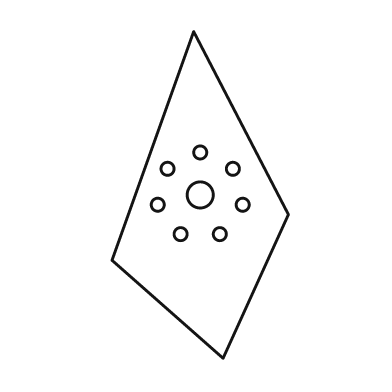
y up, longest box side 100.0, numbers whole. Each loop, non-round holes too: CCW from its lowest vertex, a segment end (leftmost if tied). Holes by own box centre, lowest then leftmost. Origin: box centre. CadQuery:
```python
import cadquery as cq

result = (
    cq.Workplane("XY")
    .moveTo(7.0, -50.0)
    .lineTo(27.0, -6.0)
    .lineTo(-2.0, 50.0)
    .lineTo(-27.0, -20.0)
    .close()
    .moveTo(-6.0, -12.0)
    .circle(2.0)
    .moveTo(6.0, -12.0)
    .circle(2.0)
    .moveTo(-13.0, -3.0)
    .circle(2.0)
    .moveTo(13.0, -3.0)
    .circle(2.0)
    .moveTo(0.0, 0.0)
    .circle(4.0)
    .moveTo(-10.0, 8.0)
    .circle(2.0)
    .moveTo(10.0, 8.0)
    .circle(2.0)
    .moveTo(0.0, 13.0)
    .circle(2.0)
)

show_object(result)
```